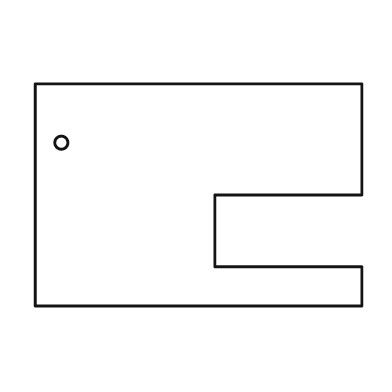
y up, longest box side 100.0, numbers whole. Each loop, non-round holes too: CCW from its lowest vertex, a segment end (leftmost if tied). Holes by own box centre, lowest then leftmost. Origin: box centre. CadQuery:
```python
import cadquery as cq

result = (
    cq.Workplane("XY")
    .moveTo(-50.0, -34.0)
    .lineTo(50.0, -34.0)
    .lineTo(50.0, -22.0)
    .lineTo(5.0, -22.0)
    .lineTo(5.0, 0.0)
    .lineTo(50.0, 0.0)
    .lineTo(50.0, 34.0)
    .lineTo(-50.0, 34.0)
    .close()
    .moveTo(-42.0, 16.0)
    .circle(2.0)
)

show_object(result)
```